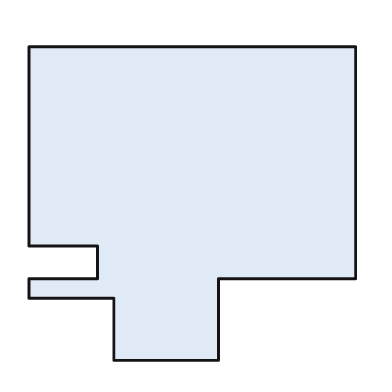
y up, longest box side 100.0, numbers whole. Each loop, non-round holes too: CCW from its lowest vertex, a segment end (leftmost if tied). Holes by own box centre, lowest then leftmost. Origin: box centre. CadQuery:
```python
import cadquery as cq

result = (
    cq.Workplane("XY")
    .moveTo(-24.0, -48.0)
    .lineTo(8.0, -48.0)
    .lineTo(8.0, -23.0)
    .lineTo(50.0, -23.0)
    .lineTo(50.0, 48.0)
    .lineTo(-50.0, 48.0)
    .lineTo(-50.0, -13.0)
    .lineTo(-29.0, -13.0)
    .lineTo(-29.0, -23.0)
    .lineTo(-50.0, -23.0)
    .lineTo(-50.0, -29.0)
    .lineTo(-24.0, -29.0)
    .close()
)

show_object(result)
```